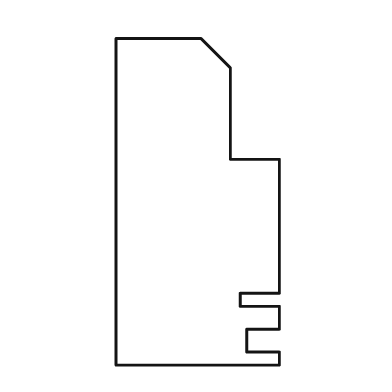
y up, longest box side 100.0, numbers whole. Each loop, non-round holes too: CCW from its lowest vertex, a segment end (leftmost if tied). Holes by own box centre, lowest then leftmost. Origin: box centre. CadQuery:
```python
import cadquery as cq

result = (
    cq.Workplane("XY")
    .moveTo(-25.0, -50.0)
    .lineTo(25.0, -50.0)
    .lineTo(25.0, -46.0)
    .lineTo(15.0, -46.0)
    .lineTo(15.0, -39.0)
    .lineTo(25.0, -39.0)
    .lineTo(25.0, -32.0)
    .lineTo(13.0, -32.0)
    .lineTo(13.0, -28.0)
    .lineTo(25.0, -28.0)
    .lineTo(25.0, 13.0)
    .lineTo(10.0, 13.0)
    .lineTo(10.0, 41.0)
    .lineTo(1.0, 50.0)
    .lineTo(-25.0, 50.0)
    .close()
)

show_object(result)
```